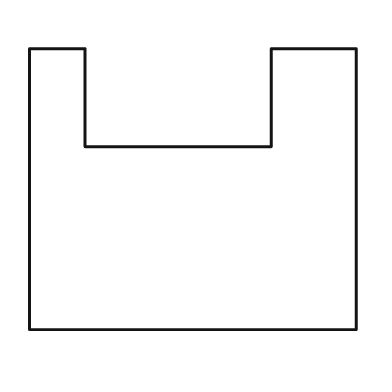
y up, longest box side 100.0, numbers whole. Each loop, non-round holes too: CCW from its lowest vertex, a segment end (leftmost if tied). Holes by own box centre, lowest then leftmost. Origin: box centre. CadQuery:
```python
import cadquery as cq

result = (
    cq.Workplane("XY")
    .moveTo(-50.0, -43.0)
    .lineTo(50.0, -43.0)
    .lineTo(50.0, 43.0)
    .lineTo(24.0, 43.0)
    .lineTo(24.0, 13.0)
    .lineTo(-33.0, 13.0)
    .lineTo(-33.0, 43.0)
    .lineTo(-50.0, 43.0)
    .close()
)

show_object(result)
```